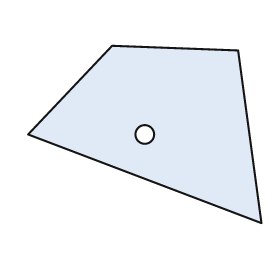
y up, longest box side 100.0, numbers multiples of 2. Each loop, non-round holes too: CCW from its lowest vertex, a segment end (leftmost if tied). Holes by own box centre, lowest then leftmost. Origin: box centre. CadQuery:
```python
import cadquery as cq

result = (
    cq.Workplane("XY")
    .moveTo(50.0, -38.0)
    .lineTo(40.0, 36.0)
    .lineTo(-14.0, 38.0)
    .lineTo(-50.0, 0.0)
    .close()
    .moveTo(0.0, 0.0)
    .circle(4.0)
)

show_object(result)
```